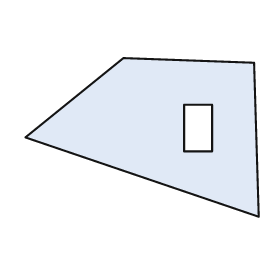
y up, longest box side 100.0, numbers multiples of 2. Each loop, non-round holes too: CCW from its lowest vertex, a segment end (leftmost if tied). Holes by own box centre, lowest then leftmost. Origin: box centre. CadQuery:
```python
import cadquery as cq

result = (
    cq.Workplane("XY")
    .moveTo(50.0, -34.0)
    .lineTo(48.0, 32.0)
    .lineTo(-8.0, 34.0)
    .lineTo(-50.0, 0.0)
    .close()
    .moveTo(18.0, -6.0)
    .lineTo(30.0, -6.0)
    .lineTo(30.0, 14.0)
    .lineTo(18.0, 14.0)
    .close()
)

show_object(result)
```